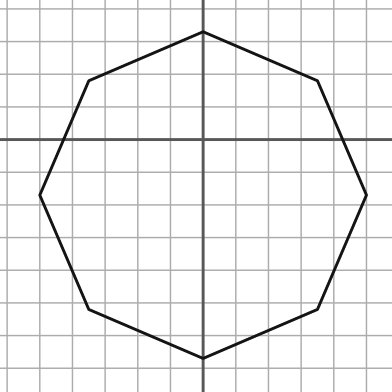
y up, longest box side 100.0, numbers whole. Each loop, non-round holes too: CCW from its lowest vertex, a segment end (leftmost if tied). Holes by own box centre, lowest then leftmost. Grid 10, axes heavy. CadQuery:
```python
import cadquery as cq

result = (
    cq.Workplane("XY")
    .moveTo(0.0, -67.0)
    .lineTo(35.0, -52.0)
    .lineTo(50.0, -17.0)
    .lineTo(35.0, 18.0)
    .lineTo(0.0, 33.0)
    .lineTo(-35.0, 18.0)
    .lineTo(-50.0, -17.0)
    .lineTo(-35.0, -52.0)
    .close()
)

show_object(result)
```